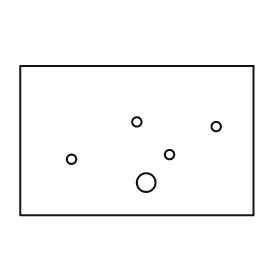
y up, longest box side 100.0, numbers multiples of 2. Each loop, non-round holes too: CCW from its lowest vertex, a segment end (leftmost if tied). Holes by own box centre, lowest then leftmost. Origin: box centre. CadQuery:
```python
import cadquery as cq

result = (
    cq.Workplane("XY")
    .moveTo(-50.0, -32.0)
    .lineTo(50.0, -32.0)
    .lineTo(50.0, 32.0)
    .lineTo(-50.0, 32.0)
    .close()
    .moveTo(4.0, -18.0)
    .circle(4.0)
    .moveTo(-28.0, -8.0)
    .circle(2.0)
    .moveTo(14.0, -6.0)
    .circle(2.0)
    .moveTo(34.0, 6.0)
    .circle(2.0)
    .moveTo(0.0, 8.0)
    .circle(2.0)
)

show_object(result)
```